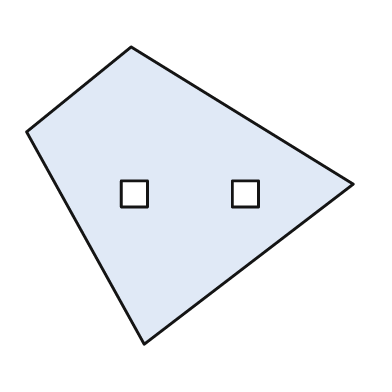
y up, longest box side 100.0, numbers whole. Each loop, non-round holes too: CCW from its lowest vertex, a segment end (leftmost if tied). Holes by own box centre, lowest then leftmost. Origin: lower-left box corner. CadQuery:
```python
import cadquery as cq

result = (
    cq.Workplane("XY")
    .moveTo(36.0, 0.0)
    .lineTo(100.0, 49.0)
    .lineTo(32.0, 91.0)
    .lineTo(0.0, 65.0)
    .close()
    .moveTo(29.0, 42.0)
    .lineTo(37.0, 42.0)
    .lineTo(37.0, 50.0)
    .lineTo(29.0, 50.0)
    .close()
    .moveTo(63.0, 42.0)
    .lineTo(71.0, 42.0)
    .lineTo(71.0, 50.0)
    .lineTo(63.0, 50.0)
    .close()
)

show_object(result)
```